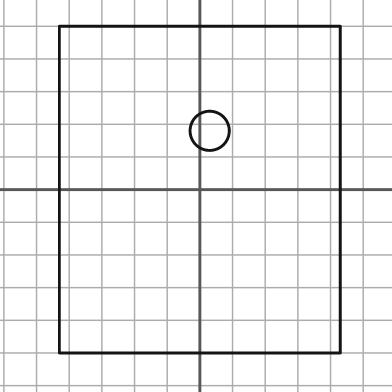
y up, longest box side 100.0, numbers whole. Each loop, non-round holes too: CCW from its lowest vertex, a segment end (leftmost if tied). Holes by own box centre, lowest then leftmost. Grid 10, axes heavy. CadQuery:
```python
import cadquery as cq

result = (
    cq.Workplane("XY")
    .moveTo(-43.0, -50.0)
    .lineTo(43.0, -50.0)
    .lineTo(43.0, 50.0)
    .lineTo(-43.0, 50.0)
    .close()
    .moveTo(3.0, 18.0)
    .circle(6.0)
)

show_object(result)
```